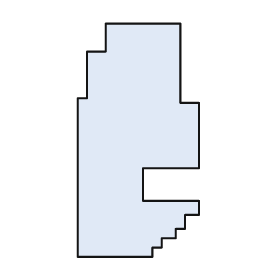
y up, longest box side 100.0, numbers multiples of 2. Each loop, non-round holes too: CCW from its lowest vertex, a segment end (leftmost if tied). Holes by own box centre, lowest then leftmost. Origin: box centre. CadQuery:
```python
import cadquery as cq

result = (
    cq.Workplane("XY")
    .moveTo(-26.0, -50.0)
    .lineTo(6.0, -50.0)
    .lineTo(6.0, -46.0)
    .lineTo(10.0, -46.0)
    .lineTo(10.0, -42.0)
    .lineTo(16.0, -42.0)
    .lineTo(16.0, -38.0)
    .lineTo(20.0, -38.0)
    .lineTo(20.0, -32.0)
    .lineTo(26.0, -32.0)
    .lineTo(26.0, -26.0)
    .lineTo(2.0, -26.0)
    .lineTo(2.0, -12.0)
    .lineTo(26.0, -12.0)
    .lineTo(26.0, 16.0)
    .lineTo(18.0, 16.0)
    .lineTo(18.0, 50.0)
    .lineTo(-14.0, 50.0)
    .lineTo(-14.0, 38.0)
    .lineTo(-22.0, 38.0)
    .lineTo(-22.0, 18.0)
    .lineTo(-26.0, 18.0)
    .close()
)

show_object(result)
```